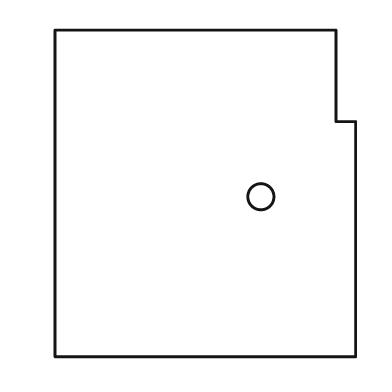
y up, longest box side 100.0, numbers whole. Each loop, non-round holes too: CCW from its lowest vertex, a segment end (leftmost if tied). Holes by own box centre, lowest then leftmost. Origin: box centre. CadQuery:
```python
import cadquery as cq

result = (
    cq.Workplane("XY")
    .moveTo(-46.0, -50.0)
    .lineTo(46.0, -50.0)
    .lineTo(46.0, 22.0)
    .lineTo(40.0, 22.0)
    .lineTo(40.0, 50.0)
    .lineTo(-46.0, 50.0)
    .close()
    .moveTo(17.0, -1.0)
    .circle(4.0)
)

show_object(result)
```